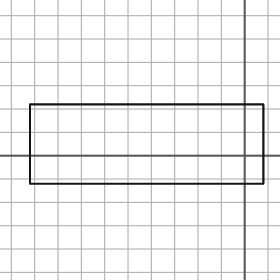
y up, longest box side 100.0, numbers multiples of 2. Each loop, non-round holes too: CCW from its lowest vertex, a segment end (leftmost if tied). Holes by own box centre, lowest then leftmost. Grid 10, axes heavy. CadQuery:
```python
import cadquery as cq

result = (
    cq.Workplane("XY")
    .moveTo(-92.0, -12.0)
    .lineTo(8.0, -12.0)
    .lineTo(8.0, 22.0)
    .lineTo(-92.0, 22.0)
    .close()
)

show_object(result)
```